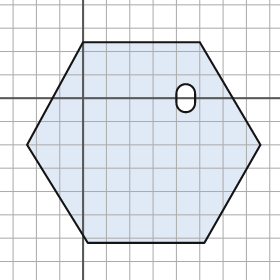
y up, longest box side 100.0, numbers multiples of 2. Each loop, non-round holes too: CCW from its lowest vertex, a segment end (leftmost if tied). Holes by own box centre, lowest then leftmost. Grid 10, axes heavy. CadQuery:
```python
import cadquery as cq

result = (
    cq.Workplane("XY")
    .moveTo(2.0, -62.0)
    .lineTo(52.0, -62.0)
    .lineTo(76.0, -20.0)
    .lineTo(50.0, 24.0)
    .lineTo(0.0, 24.0)
    .lineTo(-24.0, -20.0)
    .close()
    .moveTo(40.0, -2.0)
    .threePointArc((44.0, -6.0), (48.0, -2.0))
    .lineTo(48.0, 2.0)
    .threePointArc((44.0, 6.0), (40.0, 2.0))
    .close()
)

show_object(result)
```